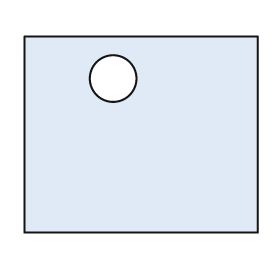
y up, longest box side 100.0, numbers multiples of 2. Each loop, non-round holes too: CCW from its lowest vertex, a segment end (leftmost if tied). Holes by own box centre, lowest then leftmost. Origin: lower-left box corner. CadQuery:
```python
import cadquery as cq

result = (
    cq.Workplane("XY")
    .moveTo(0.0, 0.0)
    .lineTo(100.0, 0.0)
    .lineTo(100.0, 84.0)
    .lineTo(0.0, 84.0)
    .close()
    .moveTo(38.0, 66.0)
    .circle(10.0)
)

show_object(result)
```